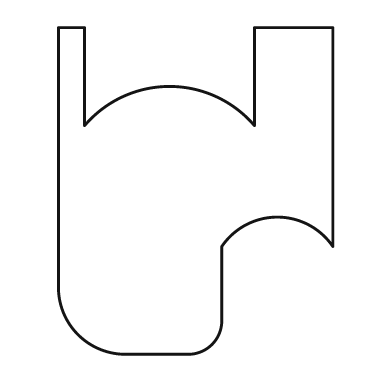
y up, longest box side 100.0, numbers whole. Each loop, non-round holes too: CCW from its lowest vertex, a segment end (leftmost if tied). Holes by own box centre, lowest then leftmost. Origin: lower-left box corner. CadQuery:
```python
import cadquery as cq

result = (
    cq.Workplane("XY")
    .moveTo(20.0, 0.0)
    .lineTo(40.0, 0.0)
    .threePointArc((47.0, 3.0), (50.0, 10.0))
    .lineTo(50.0, 33.0)
    .threePointArc((67.0, 42.0), (84.0, 33.0))
    .lineTo(84.0, 100.0)
    .lineTo(60.0, 100.0)
    .lineTo(60.0, 70.0)
    .threePointArc((34.0, 82.0), (8.0, 70.0))
    .lineTo(8.0, 100.0)
    .lineTo(0.0, 100.0)
    .lineTo(0.0, 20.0)
    .threePointArc((6.0, 6.0), (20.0, 0.0))
    .close()
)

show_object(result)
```